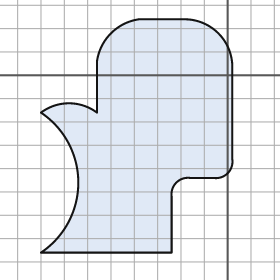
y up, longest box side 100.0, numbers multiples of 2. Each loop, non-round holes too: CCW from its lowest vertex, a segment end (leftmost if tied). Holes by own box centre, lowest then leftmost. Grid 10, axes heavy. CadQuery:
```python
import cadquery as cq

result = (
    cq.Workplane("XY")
    .moveTo(-80.0, -76.0)
    .lineTo(-24.0, -76.0)
    .lineTo(-24.0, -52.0)
    .threePointArc((-22.0, -46.0), (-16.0, -44.0))
    .lineTo(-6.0, -44.0)
    .threePointArc((0.0, -42.0), (2.0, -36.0))
    .lineTo(2.0, 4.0)
    .threePointArc((-4.0, 18.0), (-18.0, 24.0))
    .lineTo(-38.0, 24.0)
    .threePointArc((-50.0, 18.0), (-56.0, 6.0))
    .lineTo(-56.0, -16.0)
    .threePointArc((-68.0, -12.0), (-80.0, -16.0))
    .threePointArc((-64.0, -46.0), (-80.0, -76.0))
    .close()
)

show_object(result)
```